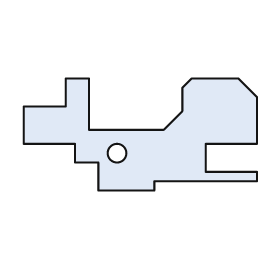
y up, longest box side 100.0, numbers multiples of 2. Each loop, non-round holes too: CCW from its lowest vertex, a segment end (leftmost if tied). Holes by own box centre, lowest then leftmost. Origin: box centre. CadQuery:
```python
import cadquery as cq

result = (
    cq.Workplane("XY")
    .moveTo(-18.0, -24.0)
    .lineTo(6.0, -24.0)
    .lineTo(6.0, -20.0)
    .lineTo(50.0, -20.0)
    .lineTo(50.0, -16.0)
    .lineTo(28.0, -16.0)
    .lineTo(28.0, -4.0)
    .lineTo(50.0, -4.0)
    .lineTo(50.0, 16.0)
    .lineTo(42.0, 24.0)
    .lineTo(22.0, 24.0)
    .lineTo(18.0, 20.0)
    .lineTo(18.0, 10.0)
    .lineTo(10.0, 2.0)
    .lineTo(-22.0, 2.0)
    .lineTo(-22.0, 24.0)
    .lineTo(-32.0, 24.0)
    .lineTo(-32.0, 12.0)
    .lineTo(-50.0, 12.0)
    .lineTo(-50.0, -4.0)
    .lineTo(-28.0, -4.0)
    .lineTo(-28.0, -12.0)
    .lineTo(-18.0, -12.0)
    .close()
    .moveTo(-10.0, -8.0)
    .circle(4.0)
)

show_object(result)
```